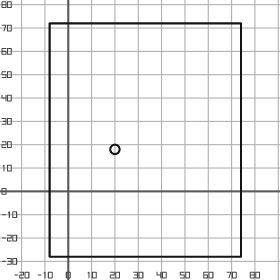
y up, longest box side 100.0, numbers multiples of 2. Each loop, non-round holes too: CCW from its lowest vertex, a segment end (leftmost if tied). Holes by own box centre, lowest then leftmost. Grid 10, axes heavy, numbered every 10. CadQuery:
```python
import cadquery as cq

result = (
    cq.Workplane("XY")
    .moveTo(-8.0, -28.0)
    .lineTo(74.0, -28.0)
    .lineTo(74.0, 72.0)
    .lineTo(-8.0, 72.0)
    .close()
    .moveTo(20.0, 18.0)
    .circle(2.0)
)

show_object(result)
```